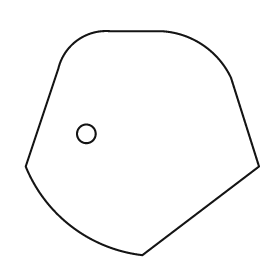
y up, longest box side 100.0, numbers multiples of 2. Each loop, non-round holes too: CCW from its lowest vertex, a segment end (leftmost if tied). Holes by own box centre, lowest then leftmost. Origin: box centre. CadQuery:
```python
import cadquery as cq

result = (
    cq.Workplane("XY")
    .moveTo(0.0, -48.0)
    .lineTo(50.0, -10.0)
    .lineTo(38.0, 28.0)
    .threePointArc((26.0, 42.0), (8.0, 48.0))
    .lineTo(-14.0, 48.0)
    .threePointArc((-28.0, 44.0), (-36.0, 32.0))
    .lineTo(-50.0, -10.0)
    .threePointArc((-30.0, -36.0), (0.0, -48.0))
    .close()
    .moveTo(-24.0, 4.0)
    .circle(4.0)
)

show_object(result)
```